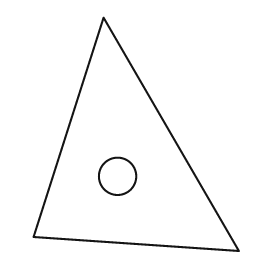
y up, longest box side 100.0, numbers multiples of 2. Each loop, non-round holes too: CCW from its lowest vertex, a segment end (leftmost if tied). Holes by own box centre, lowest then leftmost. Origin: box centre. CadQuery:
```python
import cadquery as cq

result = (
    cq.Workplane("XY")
    .moveTo(44.0, -50.0)
    .lineTo(-14.0, 50.0)
    .lineTo(-44.0, -44.0)
    .close()
    .moveTo(-8.0, -18.0)
    .circle(8.0)
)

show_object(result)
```